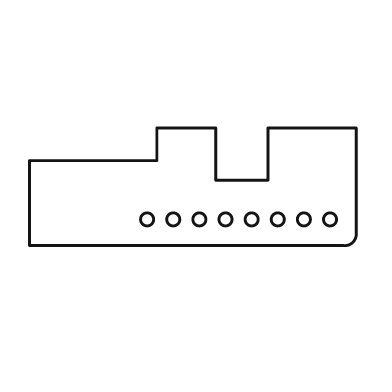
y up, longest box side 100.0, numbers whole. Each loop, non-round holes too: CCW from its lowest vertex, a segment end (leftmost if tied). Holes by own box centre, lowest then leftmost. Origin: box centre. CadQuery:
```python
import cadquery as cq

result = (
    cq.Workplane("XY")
    .moveTo(-50.0, -18.0)
    .lineTo(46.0, -18.0)
    .threePointArc((49.0, -17.0), (50.0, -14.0))
    .lineTo(50.0, 18.0)
    .lineTo(23.0, 18.0)
    .lineTo(23.0, 2.0)
    .lineTo(7.0, 2.0)
    .lineTo(7.0, 18.0)
    .lineTo(-11.0, 18.0)
    .lineTo(-11.0, 8.0)
    .lineTo(-50.0, 8.0)
    .close()
    .moveTo(-14.0, -10.0)
    .circle(2.0)
    .moveTo(-6.0, -10.0)
    .circle(2.0)
    .moveTo(2.0, -10.0)
    .circle(2.0)
    .moveTo(10.0, -10.0)
    .circle(2.0)
    .moveTo(18.0, -10.0)
    .circle(2.0)
    .moveTo(26.0, -10.0)
    .circle(2.0)
    .moveTo(34.0, -10.0)
    .circle(2.0)
    .moveTo(42.0, -10.0)
    .circle(2.0)
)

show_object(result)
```